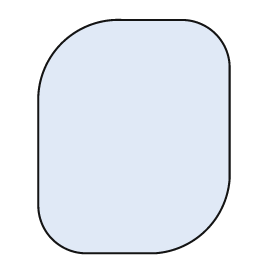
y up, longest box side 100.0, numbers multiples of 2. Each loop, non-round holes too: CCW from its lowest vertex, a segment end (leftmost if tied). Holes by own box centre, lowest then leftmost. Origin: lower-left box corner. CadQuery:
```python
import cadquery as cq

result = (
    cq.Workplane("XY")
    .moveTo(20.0, 0.0)
    .lineTo(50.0, 0.0)
    .threePointArc((72.0, 10.0), (82.0, 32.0))
    .lineTo(82.0, 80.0)
    .threePointArc((76.0, 94.0), (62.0, 100.0))
    .lineTo(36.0, 100.0)
    .threePointArc((10.0, 90.0), (0.0, 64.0))
    .lineTo(0.0, 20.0)
    .threePointArc((6.0, 6.0), (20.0, 0.0))
    .close()
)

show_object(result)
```